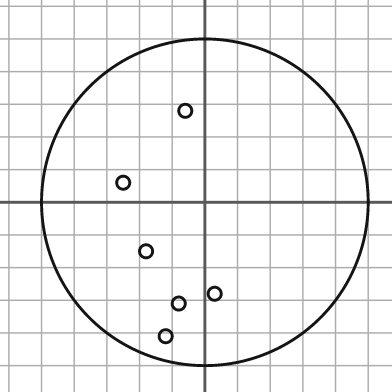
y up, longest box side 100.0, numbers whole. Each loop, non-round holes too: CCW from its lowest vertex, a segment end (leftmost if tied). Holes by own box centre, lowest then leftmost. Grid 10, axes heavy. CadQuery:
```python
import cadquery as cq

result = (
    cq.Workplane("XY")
    .moveTo(0.0, 0.0)
    .circle(50.0)
    .moveTo(-12.0, -41.0)
    .circle(2.0)
    .moveTo(-8.0, -31.0)
    .circle(2.0)
    .moveTo(3.0, -28.0)
    .circle(2.0)
    .moveTo(-18.0, -15.0)
    .circle(2.0)
    .moveTo(-25.0, 6.0)
    .circle(2.0)
    .moveTo(-6.0, 28.0)
    .circle(2.0)
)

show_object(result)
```